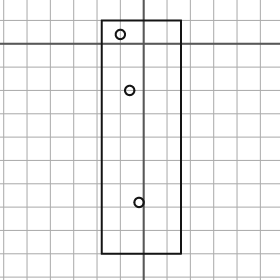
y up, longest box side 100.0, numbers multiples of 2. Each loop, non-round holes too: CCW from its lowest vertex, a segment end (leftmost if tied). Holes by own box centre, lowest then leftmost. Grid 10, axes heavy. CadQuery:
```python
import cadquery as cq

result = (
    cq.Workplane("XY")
    .moveTo(-18.0, -90.0)
    .lineTo(16.0, -90.0)
    .lineTo(16.0, 10.0)
    .lineTo(-18.0, 10.0)
    .close()
    .moveTo(-2.0, -68.0)
    .circle(2.0)
    .moveTo(-6.0, -20.0)
    .circle(2.0)
    .moveTo(-10.0, 4.0)
    .circle(2.0)
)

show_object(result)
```